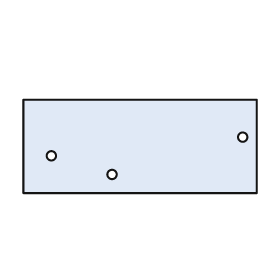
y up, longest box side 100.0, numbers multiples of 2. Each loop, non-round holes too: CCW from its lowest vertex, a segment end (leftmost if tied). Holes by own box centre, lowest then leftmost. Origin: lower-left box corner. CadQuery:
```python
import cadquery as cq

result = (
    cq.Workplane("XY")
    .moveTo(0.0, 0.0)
    .lineTo(100.0, 0.0)
    .lineTo(100.0, 40.0)
    .lineTo(0.0, 40.0)
    .close()
    .moveTo(38.0, 8.0)
    .circle(2.0)
    .moveTo(12.0, 16.0)
    .circle(2.0)
    .moveTo(94.0, 24.0)
    .circle(2.0)
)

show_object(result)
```